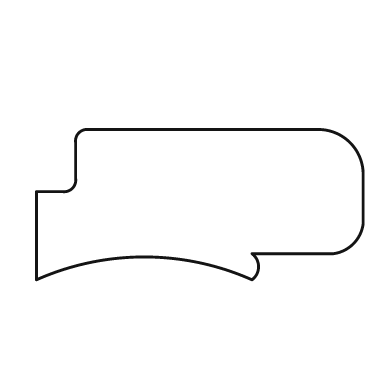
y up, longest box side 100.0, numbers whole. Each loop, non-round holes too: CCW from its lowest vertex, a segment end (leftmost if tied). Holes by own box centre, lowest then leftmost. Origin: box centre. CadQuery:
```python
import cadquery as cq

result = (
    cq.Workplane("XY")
    .moveTo(-50.0, -23.0)
    .threePointArc((-17.0, -16.0), (16.0, -23.0))
    .threePointArc((18.0, -19.0), (16.0, -15.0))
    .lineTo(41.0, -15.0)
    .threePointArc((47.0, -12.0), (50.0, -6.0))
    .lineTo(50.0, 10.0)
    .threePointArc((46.0, 19.0), (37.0, 23.0))
    .lineTo(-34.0, 23.0)
    .threePointArc((-37.0, 22.0), (-38.0, 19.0))
    .lineTo(-38.0, 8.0)
    .threePointArc((-39.0, 5.0), (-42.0, 4.0))
    .lineTo(-50.0, 4.0)
    .close()
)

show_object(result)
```